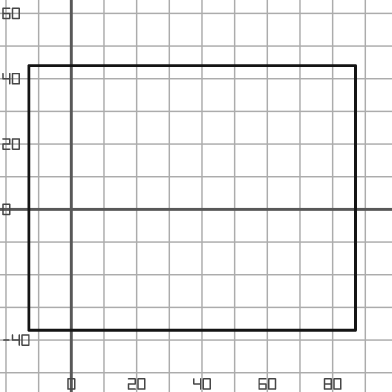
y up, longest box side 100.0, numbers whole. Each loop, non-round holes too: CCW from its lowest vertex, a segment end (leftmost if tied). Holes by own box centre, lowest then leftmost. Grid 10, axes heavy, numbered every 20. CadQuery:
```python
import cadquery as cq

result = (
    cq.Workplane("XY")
    .moveTo(-13.0, -37.0)
    .lineTo(87.0, -37.0)
    .lineTo(87.0, 44.0)
    .lineTo(-13.0, 44.0)
    .close()
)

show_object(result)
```